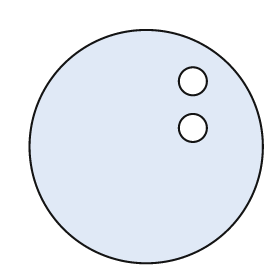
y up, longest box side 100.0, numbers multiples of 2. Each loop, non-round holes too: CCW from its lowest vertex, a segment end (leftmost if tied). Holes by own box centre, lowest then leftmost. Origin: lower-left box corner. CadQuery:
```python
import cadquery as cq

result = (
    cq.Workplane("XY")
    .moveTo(50.0, 50.0)
    .circle(50.0)
    .moveTo(70.0, 58.0)
    .circle(6.0)
    .moveTo(70.0, 78.0)
    .circle(6.0)
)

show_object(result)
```